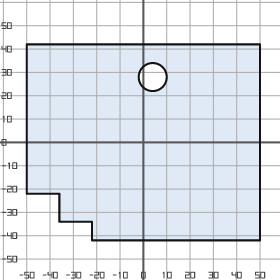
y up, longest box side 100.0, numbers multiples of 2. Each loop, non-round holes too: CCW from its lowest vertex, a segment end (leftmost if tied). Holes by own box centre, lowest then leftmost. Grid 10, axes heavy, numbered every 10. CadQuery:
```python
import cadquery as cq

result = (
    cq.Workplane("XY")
    .moveTo(-22.0, -42.0)
    .lineTo(50.0, -42.0)
    .lineTo(50.0, 42.0)
    .lineTo(-50.0, 42.0)
    .lineTo(-50.0, -22.0)
    .lineTo(-36.0, -22.0)
    .lineTo(-36.0, -34.0)
    .lineTo(-22.0, -34.0)
    .close()
    .moveTo(4.0, 28.0)
    .circle(6.0)
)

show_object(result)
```